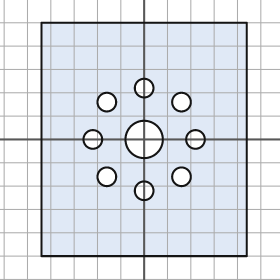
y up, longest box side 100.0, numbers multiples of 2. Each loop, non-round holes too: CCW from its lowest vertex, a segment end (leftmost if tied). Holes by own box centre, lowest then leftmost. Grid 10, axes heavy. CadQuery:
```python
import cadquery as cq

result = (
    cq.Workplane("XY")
    .moveTo(-44.0, -50.0)
    .lineTo(44.0, -50.0)
    .lineTo(44.0, 50.0)
    .lineTo(-44.0, 50.0)
    .close()
    .moveTo(0.0, -22.0)
    .circle(4.0)
    .moveTo(-16.0, -16.0)
    .circle(4.0)
    .moveTo(16.0, -16.0)
    .circle(4.0)
    .moveTo(-22.0, 0.0)
    .circle(4.0)
    .moveTo(0.0, 0.0)
    .circle(8.0)
    .moveTo(22.0, 0.0)
    .circle(4.0)
    .moveTo(-16.0, 16.0)
    .circle(4.0)
    .moveTo(16.0, 16.0)
    .circle(4.0)
    .moveTo(0.0, 22.0)
    .circle(4.0)
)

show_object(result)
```